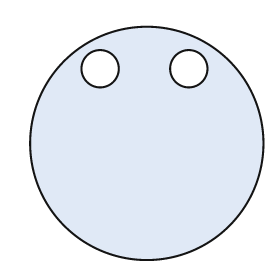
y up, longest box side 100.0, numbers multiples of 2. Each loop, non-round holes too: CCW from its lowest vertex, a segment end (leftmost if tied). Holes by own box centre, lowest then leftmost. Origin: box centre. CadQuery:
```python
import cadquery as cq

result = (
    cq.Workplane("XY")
    .moveTo(0.0, 0.0)
    .circle(50.0)
    .moveTo(-20.0, 32.0)
    .circle(8.0)
    .moveTo(18.0, 32.0)
    .circle(8.0)
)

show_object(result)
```